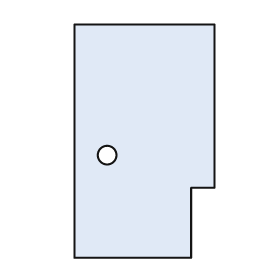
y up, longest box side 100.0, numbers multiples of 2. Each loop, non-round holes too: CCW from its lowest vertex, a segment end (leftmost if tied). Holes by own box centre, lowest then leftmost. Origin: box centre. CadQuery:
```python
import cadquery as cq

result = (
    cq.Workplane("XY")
    .moveTo(-30.0, -50.0)
    .lineTo(20.0, -50.0)
    .lineTo(20.0, -20.0)
    .lineTo(30.0, -20.0)
    .lineTo(30.0, 50.0)
    .lineTo(-30.0, 50.0)
    .close()
    .moveTo(-16.0, -6.0)
    .circle(4.0)
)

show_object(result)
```